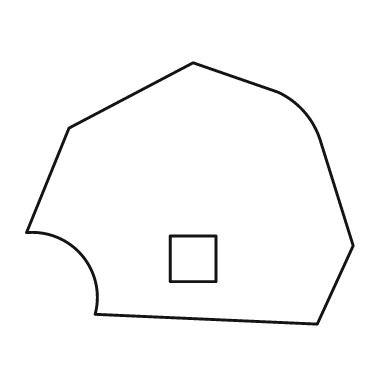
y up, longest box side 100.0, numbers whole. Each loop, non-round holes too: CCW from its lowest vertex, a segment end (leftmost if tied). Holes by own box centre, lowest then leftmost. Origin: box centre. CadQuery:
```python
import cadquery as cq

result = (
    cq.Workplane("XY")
    .moveTo(39.0, -40.0)
    .lineTo(50.0, -16.0)
    .lineTo(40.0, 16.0)
    .threePointArc((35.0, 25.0), (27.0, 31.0))
    .lineTo(1.0, 40.0)
    .lineTo(-37.0, 20.0)
    .lineTo(-50.0, -12.0)
    .threePointArc((-33.0, -19.0), (-29.0, -37.0))
    .close()
    .moveTo(-6.0, -27.0)
    .lineTo(8.0, -27.0)
    .lineTo(8.0, -13.0)
    .lineTo(-6.0, -13.0)
    .close()
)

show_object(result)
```